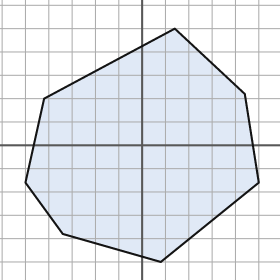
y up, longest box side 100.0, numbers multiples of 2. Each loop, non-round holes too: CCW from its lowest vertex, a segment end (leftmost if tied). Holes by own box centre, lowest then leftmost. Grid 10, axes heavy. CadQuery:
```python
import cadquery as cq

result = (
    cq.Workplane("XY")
    .moveTo(8.0, -50.0)
    .lineTo(50.0, -16.0)
    .lineTo(44.0, 22.0)
    .lineTo(14.0, 50.0)
    .lineTo(-42.0, 20.0)
    .lineTo(-50.0, -16.0)
    .lineTo(-34.0, -38.0)
    .close()
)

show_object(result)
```